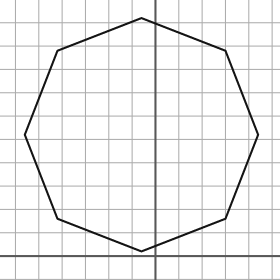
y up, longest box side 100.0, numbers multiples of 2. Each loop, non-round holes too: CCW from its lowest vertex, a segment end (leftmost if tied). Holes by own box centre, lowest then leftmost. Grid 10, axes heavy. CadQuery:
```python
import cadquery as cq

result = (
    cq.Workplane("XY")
    .moveTo(-6.0, 2.0)
    .lineTo(30.0, 16.0)
    .lineTo(44.0, 52.0)
    .lineTo(30.0, 88.0)
    .lineTo(-6.0, 102.0)
    .lineTo(-42.0, 88.0)
    .lineTo(-56.0, 52.0)
    .lineTo(-42.0, 16.0)
    .close()
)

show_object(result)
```